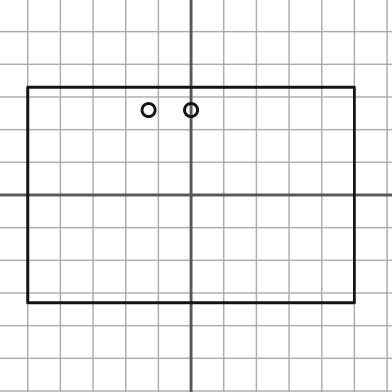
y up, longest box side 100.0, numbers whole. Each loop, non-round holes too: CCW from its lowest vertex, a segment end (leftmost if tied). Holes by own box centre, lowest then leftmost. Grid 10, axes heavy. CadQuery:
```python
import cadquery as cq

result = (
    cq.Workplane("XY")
    .moveTo(-50.0, -33.0)
    .lineTo(50.0, -33.0)
    .lineTo(50.0, 33.0)
    .lineTo(-50.0, 33.0)
    .close()
    .moveTo(-13.0, 26.0)
    .circle(2.0)
    .moveTo(0.0, 26.0)
    .circle(2.0)
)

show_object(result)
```